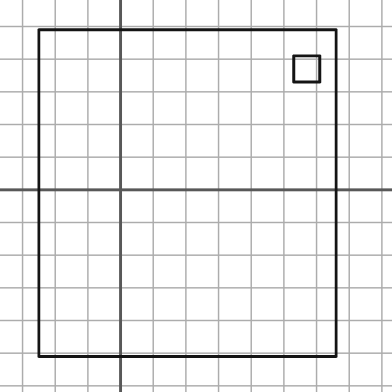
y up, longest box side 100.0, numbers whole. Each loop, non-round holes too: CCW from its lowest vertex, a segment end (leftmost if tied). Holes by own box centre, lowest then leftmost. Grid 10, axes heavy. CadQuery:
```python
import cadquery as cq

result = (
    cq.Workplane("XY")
    .moveTo(-25.0, -51.0)
    .lineTo(66.0, -51.0)
    .lineTo(66.0, 49.0)
    .lineTo(-25.0, 49.0)
    .close()
    .moveTo(53.0, 33.0)
    .lineTo(61.0, 33.0)
    .lineTo(61.0, 41.0)
    .lineTo(53.0, 41.0)
    .close()
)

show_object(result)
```